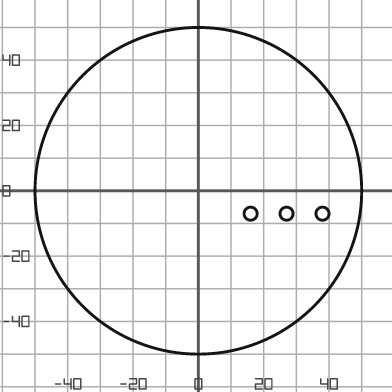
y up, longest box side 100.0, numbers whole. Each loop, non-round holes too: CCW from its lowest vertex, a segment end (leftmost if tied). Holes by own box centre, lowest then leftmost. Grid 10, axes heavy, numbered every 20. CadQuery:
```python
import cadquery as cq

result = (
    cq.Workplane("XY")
    .moveTo(0.0, 0.0)
    .circle(50.0)
    .moveTo(16.0, -7.0)
    .circle(2.0)
    .moveTo(27.0, -7.0)
    .circle(2.0)
    .moveTo(38.0, -7.0)
    .circle(2.0)
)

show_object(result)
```